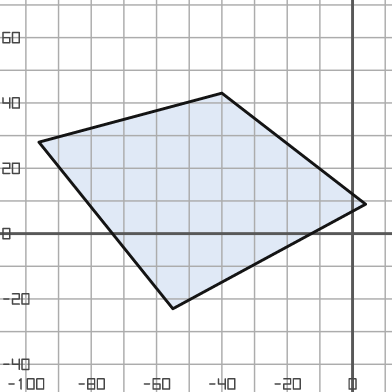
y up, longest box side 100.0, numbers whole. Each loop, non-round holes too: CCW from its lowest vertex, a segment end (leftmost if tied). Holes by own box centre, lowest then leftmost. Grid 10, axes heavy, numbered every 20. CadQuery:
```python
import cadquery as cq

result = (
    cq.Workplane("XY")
    .moveTo(-55.0, -23.0)
    .lineTo(4.0, 9.0)
    .lineTo(-40.0, 43.0)
    .lineTo(-96.0, 28.0)
    .close()
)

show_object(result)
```